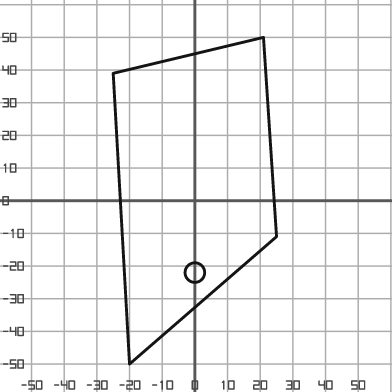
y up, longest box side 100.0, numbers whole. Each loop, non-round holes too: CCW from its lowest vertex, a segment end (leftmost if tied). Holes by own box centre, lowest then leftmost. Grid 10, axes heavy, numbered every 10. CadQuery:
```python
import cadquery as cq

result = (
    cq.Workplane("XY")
    .moveTo(-20.0, -50.0)
    .lineTo(25.0, -11.0)
    .lineTo(21.0, 50.0)
    .lineTo(-25.0, 39.0)
    .close()
    .moveTo(0.0, -22.0)
    .circle(3.0)
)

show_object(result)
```